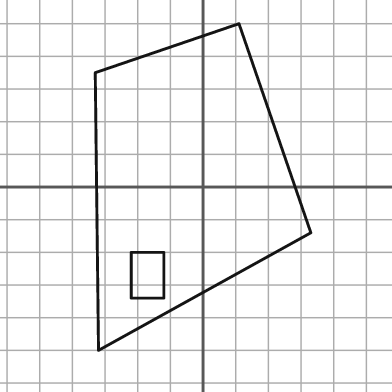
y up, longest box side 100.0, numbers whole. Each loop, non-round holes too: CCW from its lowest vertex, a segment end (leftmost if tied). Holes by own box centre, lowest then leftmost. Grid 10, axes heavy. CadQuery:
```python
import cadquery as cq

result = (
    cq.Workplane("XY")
    .moveTo(-32.0, -50.0)
    .lineTo(33.0, -14.0)
    .lineTo(11.0, 50.0)
    .lineTo(-33.0, 35.0)
    .close()
    .moveTo(-22.0, -34.0)
    .lineTo(-12.0, -34.0)
    .lineTo(-12.0, -20.0)
    .lineTo(-22.0, -20.0)
    .close()
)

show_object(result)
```